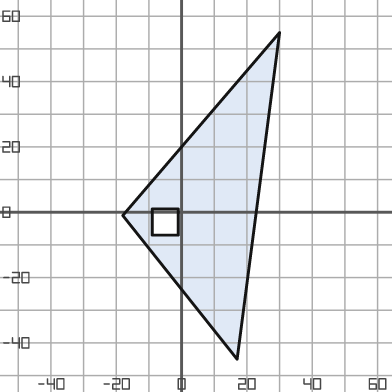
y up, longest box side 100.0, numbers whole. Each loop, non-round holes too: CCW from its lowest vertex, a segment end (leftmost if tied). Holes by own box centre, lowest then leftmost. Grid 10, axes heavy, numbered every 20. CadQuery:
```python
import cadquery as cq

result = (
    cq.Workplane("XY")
    .moveTo(17.0, -45.0)
    .lineTo(30.0, 55.0)
    .lineTo(-18.0, -1.0)
    .close()
    .moveTo(-9.0, -7.0)
    .lineTo(-1.0, -7.0)
    .lineTo(-1.0, 1.0)
    .lineTo(-9.0, 1.0)
    .close()
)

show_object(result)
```